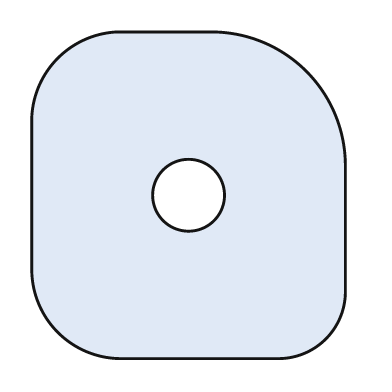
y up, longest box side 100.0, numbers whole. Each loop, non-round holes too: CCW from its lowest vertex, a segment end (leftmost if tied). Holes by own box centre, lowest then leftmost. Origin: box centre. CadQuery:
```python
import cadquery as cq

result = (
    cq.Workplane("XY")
    .moveTo(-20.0, -50.0)
    .lineTo(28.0, -50.0)
    .threePointArc((42.0, -44.0), (48.0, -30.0))
    .lineTo(48.0, 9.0)
    .threePointArc((36.0, 38.0), (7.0, 50.0))
    .lineTo(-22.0, 50.0)
    .threePointArc((-40.0, 42.0), (-48.0, 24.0))
    .lineTo(-48.0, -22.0)
    .threePointArc((-40.0, -42.0), (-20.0, -50.0))
    .close()
    .moveTo(0.0, 0.0)
    .circle(11.0)
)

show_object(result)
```